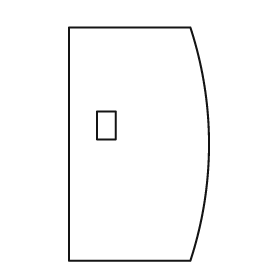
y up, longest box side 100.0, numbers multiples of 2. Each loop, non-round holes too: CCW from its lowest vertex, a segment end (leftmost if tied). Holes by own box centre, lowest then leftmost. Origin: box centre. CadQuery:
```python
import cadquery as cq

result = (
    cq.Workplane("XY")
    .moveTo(-30.0, -50.0)
    .lineTo(22.0, -50.0)
    .threePointArc((30.0, 0.0), (22.0, 50.0))
    .lineTo(-30.0, 50.0)
    .close()
    .moveTo(-18.0, 2.0)
    .lineTo(-10.0, 2.0)
    .lineTo(-10.0, 14.0)
    .lineTo(-18.0, 14.0)
    .close()
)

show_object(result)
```